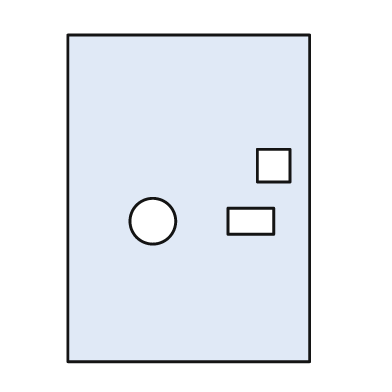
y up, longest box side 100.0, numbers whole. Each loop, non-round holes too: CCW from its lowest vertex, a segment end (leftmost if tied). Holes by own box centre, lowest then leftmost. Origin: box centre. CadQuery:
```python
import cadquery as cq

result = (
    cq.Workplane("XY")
    .moveTo(-37.0, -50.0)
    .lineTo(37.0, -50.0)
    .lineTo(37.0, 50.0)
    .lineTo(-37.0, 50.0)
    .close()
    .moveTo(-11.0, -7.0)
    .circle(7.0)
    .moveTo(12.0, -11.0)
    .lineTo(26.0, -11.0)
    .lineTo(26.0, -3.0)
    .lineTo(12.0, -3.0)
    .close()
    .moveTo(21.0, 5.0)
    .lineTo(31.0, 5.0)
    .lineTo(31.0, 15.0)
    .lineTo(21.0, 15.0)
    .close()
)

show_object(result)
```